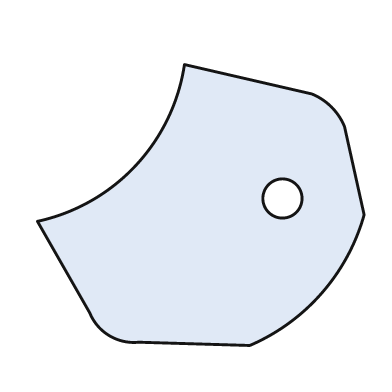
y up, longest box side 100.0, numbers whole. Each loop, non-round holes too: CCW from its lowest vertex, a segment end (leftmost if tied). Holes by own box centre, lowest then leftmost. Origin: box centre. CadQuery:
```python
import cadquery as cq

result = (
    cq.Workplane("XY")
    .moveTo(15.0, -43.0)
    .threePointArc((37.0, -27.0), (50.0, -3.0))
    .lineTo(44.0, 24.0)
    .threePointArc((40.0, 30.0), (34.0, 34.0))
    .lineTo(-5.0, 43.0)
    .threePointArc((-20.0, 12.0), (-50.0, -5.0))
    .lineTo(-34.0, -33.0)
    .threePointArc((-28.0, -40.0), (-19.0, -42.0))
    .close()
    .moveTo(25.0, 2.0)
    .circle(6.0)
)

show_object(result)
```